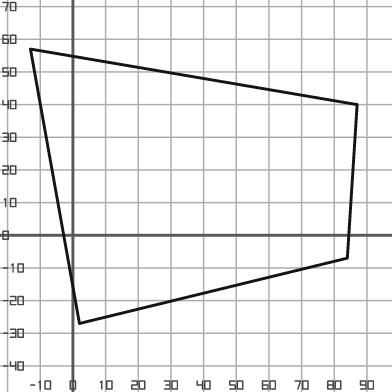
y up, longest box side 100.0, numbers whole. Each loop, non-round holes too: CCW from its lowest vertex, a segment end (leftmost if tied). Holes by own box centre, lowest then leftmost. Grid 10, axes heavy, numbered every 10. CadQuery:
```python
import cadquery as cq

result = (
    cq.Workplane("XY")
    .moveTo(2.0, -27.0)
    .lineTo(84.0, -7.0)
    .lineTo(87.0, 40.0)
    .lineTo(-13.0, 57.0)
    .close()
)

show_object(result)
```